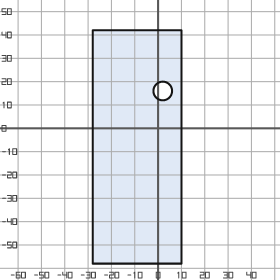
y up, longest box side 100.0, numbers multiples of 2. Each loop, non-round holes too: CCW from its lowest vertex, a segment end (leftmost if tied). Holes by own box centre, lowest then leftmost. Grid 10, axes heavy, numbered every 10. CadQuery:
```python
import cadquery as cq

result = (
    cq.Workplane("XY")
    .moveTo(-28.0, -58.0)
    .lineTo(10.0, -58.0)
    .lineTo(10.0, 42.0)
    .lineTo(-28.0, 42.0)
    .close()
    .moveTo(2.0, 16.0)
    .circle(4.0)
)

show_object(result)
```